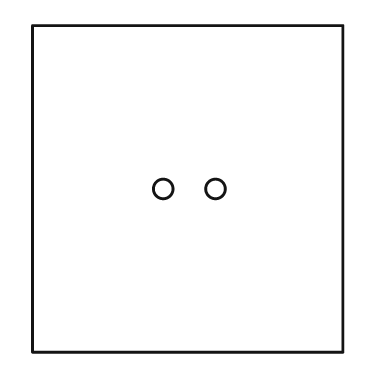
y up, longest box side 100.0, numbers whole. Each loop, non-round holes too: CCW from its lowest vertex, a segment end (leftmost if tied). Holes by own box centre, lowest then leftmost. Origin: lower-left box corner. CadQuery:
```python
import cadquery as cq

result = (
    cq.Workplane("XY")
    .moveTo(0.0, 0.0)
    .lineTo(95.0, 0.0)
    .lineTo(95.0, 100.0)
    .lineTo(0.0, 100.0)
    .close()
    .moveTo(40.0, 50.0)
    .circle(3.0)
    .moveTo(56.0, 50.0)
    .circle(3.0)
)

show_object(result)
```